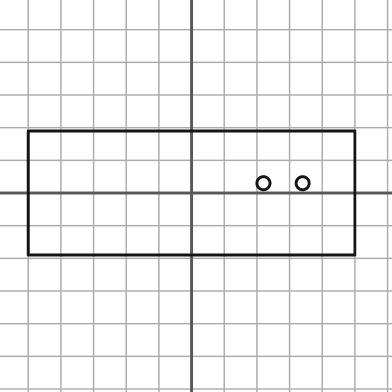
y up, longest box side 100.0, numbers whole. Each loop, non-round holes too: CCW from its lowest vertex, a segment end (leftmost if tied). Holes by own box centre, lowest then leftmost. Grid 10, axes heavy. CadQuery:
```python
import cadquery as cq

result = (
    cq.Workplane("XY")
    .moveTo(-50.0, -19.0)
    .lineTo(50.0, -19.0)
    .lineTo(50.0, 19.0)
    .lineTo(-50.0, 19.0)
    .close()
    .moveTo(22.0, 3.0)
    .circle(2.0)
    .moveTo(34.0, 3.0)
    .circle(2.0)
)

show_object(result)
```